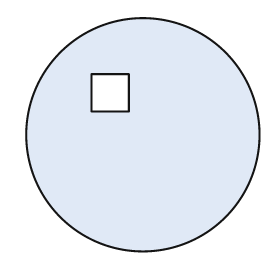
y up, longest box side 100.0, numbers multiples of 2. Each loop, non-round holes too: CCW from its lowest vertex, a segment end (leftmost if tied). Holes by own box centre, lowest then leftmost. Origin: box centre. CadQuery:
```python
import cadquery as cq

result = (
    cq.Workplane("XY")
    .moveTo(0.0, 0.0)
    .circle(50.0)
    .moveTo(-22.0, 10.0)
    .lineTo(-6.0, 10.0)
    .lineTo(-6.0, 26.0)
    .lineTo(-22.0, 26.0)
    .close()
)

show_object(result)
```